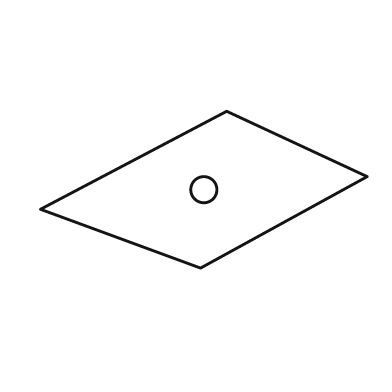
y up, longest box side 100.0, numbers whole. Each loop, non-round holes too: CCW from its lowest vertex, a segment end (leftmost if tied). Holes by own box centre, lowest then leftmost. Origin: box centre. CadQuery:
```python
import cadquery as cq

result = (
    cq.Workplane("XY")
    .moveTo(-1.0, -24.0)
    .lineTo(50.0, 4.0)
    .lineTo(7.0, 24.0)
    .lineTo(-50.0, -6.0)
    .close()
    .moveTo(0.0, 0.0)
    .circle(4.0)
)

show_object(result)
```